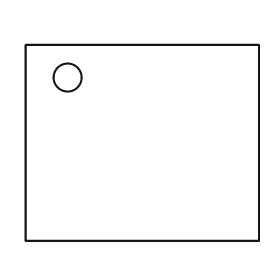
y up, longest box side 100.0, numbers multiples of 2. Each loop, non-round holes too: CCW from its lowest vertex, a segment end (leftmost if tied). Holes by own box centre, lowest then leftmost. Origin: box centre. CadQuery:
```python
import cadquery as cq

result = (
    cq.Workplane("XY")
    .moveTo(-50.0, -42.0)
    .lineTo(50.0, -42.0)
    .lineTo(50.0, 42.0)
    .lineTo(-50.0, 42.0)
    .close()
    .moveTo(-32.0, 28.0)
    .circle(6.0)
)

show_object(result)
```